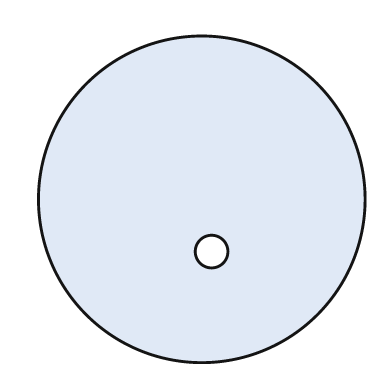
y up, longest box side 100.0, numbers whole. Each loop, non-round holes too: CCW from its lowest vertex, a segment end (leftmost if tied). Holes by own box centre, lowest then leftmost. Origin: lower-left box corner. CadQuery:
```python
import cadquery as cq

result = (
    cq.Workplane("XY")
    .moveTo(50.0, 50.0)
    .circle(50.0)
    .moveTo(53.0, 34.0)
    .circle(5.0)
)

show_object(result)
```